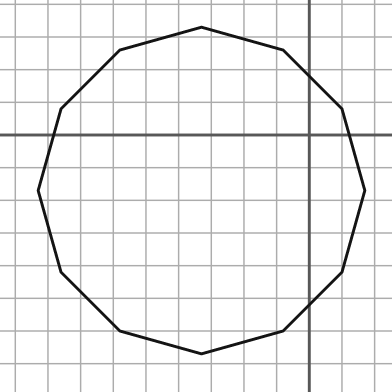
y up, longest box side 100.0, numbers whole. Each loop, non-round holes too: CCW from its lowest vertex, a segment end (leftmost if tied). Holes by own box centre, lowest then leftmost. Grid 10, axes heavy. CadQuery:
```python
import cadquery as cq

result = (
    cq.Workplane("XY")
    .moveTo(-33.0, -67.0)
    .lineTo(-8.0, -60.0)
    .lineTo(10.0, -42.0)
    .lineTo(17.0, -17.0)
    .lineTo(10.0, 8.0)
    .lineTo(-8.0, 26.0)
    .lineTo(-33.0, 33.0)
    .lineTo(-58.0, 26.0)
    .lineTo(-76.0, 8.0)
    .lineTo(-83.0, -17.0)
    .lineTo(-76.0, -42.0)
    .lineTo(-58.0, -60.0)
    .close()
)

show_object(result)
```